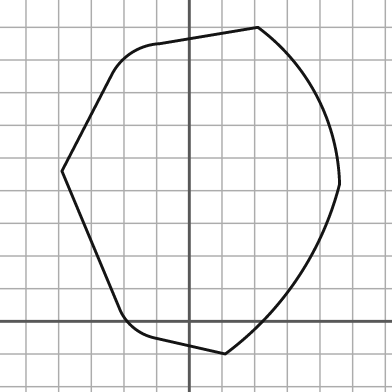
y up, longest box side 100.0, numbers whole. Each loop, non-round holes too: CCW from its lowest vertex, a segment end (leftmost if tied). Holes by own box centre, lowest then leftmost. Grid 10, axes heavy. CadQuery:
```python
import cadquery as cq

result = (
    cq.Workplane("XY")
    .moveTo(11.0, -10.0)
    .threePointArc((33.0, 13.0), (46.0, 42.0))
    .threePointArc((39.0, 69.0), (21.0, 90.0))
    .lineTo(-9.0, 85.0)
    .threePointArc((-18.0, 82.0), (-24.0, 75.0))
    .lineTo(-39.0, 46.0)
    .lineTo(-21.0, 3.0)
    .threePointArc((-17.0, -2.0), (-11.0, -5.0))
    .close()
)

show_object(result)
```